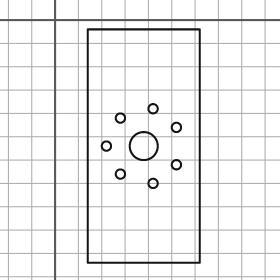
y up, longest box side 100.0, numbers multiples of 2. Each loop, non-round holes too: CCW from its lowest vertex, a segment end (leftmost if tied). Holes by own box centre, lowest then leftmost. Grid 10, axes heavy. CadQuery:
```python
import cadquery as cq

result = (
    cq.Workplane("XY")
    .moveTo(14.0, -104.0)
    .lineTo(62.0, -104.0)
    .lineTo(62.0, -4.0)
    .lineTo(14.0, -4.0)
    .close()
    .moveTo(42.0, -70.0)
    .circle(2.0)
    .moveTo(28.0, -66.0)
    .circle(2.0)
    .moveTo(52.0, -62.0)
    .circle(2.0)
    .moveTo(22.0, -54.0)
    .circle(2.0)
    .moveTo(38.0, -54.0)
    .circle(6.0)
    .moveTo(52.0, -46.0)
    .circle(2.0)
    .moveTo(28.0, -42.0)
    .circle(2.0)
    .moveTo(42.0, -38.0)
    .circle(2.0)
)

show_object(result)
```